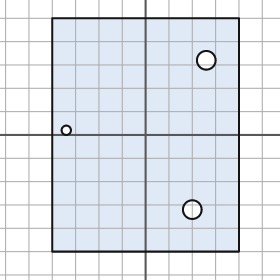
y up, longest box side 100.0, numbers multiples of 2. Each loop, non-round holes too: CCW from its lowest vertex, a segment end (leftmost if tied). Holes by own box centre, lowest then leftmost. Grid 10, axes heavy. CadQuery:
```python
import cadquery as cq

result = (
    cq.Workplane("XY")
    .moveTo(-40.0, -50.0)
    .lineTo(40.0, -50.0)
    .lineTo(40.0, 50.0)
    .lineTo(-40.0, 50.0)
    .close()
    .moveTo(20.0, -32.0)
    .circle(4.0)
    .moveTo(-34.0, 2.0)
    .circle(2.0)
    .moveTo(26.0, 32.0)
    .circle(4.0)
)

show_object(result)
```